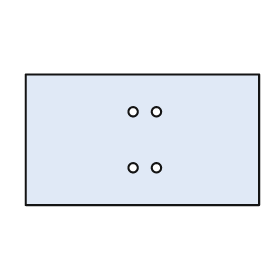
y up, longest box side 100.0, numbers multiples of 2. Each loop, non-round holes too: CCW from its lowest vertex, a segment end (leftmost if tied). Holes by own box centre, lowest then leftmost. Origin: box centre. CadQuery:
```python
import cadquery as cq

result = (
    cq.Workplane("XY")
    .moveTo(-50.0, -28.0)
    .lineTo(50.0, -28.0)
    .lineTo(50.0, 28.0)
    .lineTo(-50.0, 28.0)
    .close()
    .moveTo(-4.0, -12.0)
    .circle(2.0)
    .moveTo(6.0, -12.0)
    .circle(2.0)
    .moveTo(-4.0, 12.0)
    .circle(2.0)
    .moveTo(6.0, 12.0)
    .circle(2.0)
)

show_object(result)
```